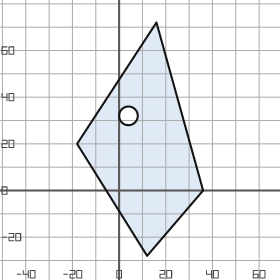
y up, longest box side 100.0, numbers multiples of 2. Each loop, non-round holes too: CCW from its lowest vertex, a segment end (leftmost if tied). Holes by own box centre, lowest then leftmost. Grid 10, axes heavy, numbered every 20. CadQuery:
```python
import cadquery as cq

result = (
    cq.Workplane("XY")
    .moveTo(12.0, -28.0)
    .lineTo(36.0, 0.0)
    .lineTo(16.0, 72.0)
    .lineTo(-18.0, 20.0)
    .close()
    .moveTo(4.0, 32.0)
    .circle(4.0)
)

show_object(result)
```